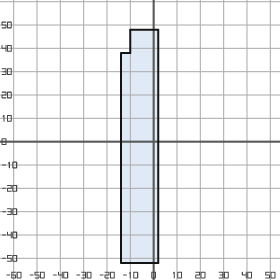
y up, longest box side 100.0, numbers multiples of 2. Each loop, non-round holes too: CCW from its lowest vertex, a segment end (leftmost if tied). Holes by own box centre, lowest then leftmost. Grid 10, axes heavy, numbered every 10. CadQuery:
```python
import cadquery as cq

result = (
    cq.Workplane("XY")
    .moveTo(-14.0, -52.0)
    .lineTo(2.0, -52.0)
    .lineTo(2.0, 48.0)
    .lineTo(-10.0, 48.0)
    .lineTo(-10.0, 38.0)
    .lineTo(-14.0, 38.0)
    .close()
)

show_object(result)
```